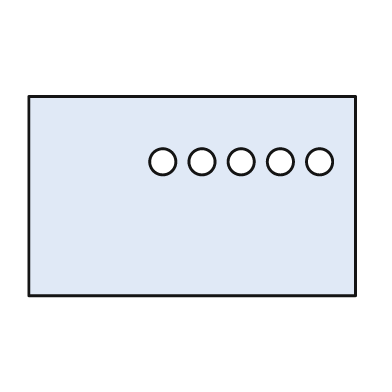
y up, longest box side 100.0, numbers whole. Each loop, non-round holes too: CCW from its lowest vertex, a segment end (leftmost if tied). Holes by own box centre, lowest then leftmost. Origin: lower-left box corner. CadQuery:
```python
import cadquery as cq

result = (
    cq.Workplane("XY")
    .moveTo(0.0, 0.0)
    .lineTo(100.0, 0.0)
    .lineTo(100.0, 61.0)
    .lineTo(0.0, 61.0)
    .close()
    .moveTo(41.0, 41.0)
    .circle(4.0)
    .moveTo(53.0, 41.0)
    .circle(4.0)
    .moveTo(65.0, 41.0)
    .circle(4.0)
    .moveTo(77.0, 41.0)
    .circle(4.0)
    .moveTo(89.0, 41.0)
    .circle(4.0)
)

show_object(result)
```